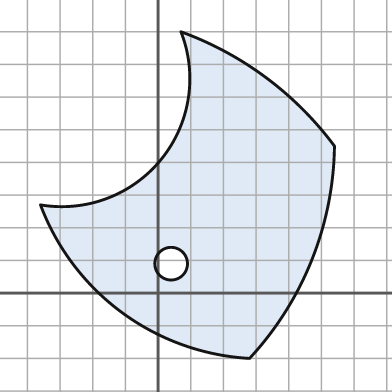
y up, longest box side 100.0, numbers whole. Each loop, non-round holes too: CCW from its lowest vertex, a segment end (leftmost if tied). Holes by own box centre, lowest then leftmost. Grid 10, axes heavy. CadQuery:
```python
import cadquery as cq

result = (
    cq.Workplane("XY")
    .moveTo(28.0, -20.0)
    .threePointArc((47.0, 10.0), (54.0, 45.0))
    .threePointArc((33.0, 66.0), (7.0, 80.0))
    .threePointArc((1.0, 41.0), (-36.0, 27.0))
    .threePointArc((-11.0, -6.0), (28.0, -20.0))
    .close()
    .moveTo(4.0, 9.0)
    .circle(5.0)
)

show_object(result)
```